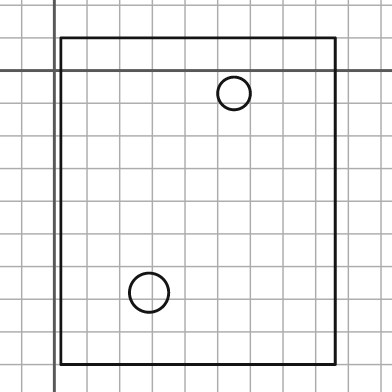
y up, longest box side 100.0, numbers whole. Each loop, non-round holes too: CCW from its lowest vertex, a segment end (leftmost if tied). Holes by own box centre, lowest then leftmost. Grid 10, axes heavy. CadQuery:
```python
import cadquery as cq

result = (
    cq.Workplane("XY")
    .moveTo(2.0, -90.0)
    .lineTo(86.0, -90.0)
    .lineTo(86.0, 10.0)
    .lineTo(2.0, 10.0)
    .close()
    .moveTo(29.0, -68.0)
    .circle(6.0)
    .moveTo(55.0, -7.0)
    .circle(5.0)
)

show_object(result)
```